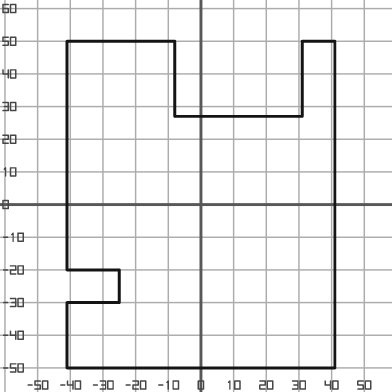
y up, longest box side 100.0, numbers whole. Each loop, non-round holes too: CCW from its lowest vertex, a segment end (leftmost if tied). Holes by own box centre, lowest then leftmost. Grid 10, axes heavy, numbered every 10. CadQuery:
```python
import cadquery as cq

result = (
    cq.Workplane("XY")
    .moveTo(-41.0, -50.0)
    .lineTo(41.0, -50.0)
    .lineTo(41.0, 50.0)
    .lineTo(31.0, 50.0)
    .lineTo(31.0, 27.0)
    .lineTo(-8.0, 27.0)
    .lineTo(-8.0, 50.0)
    .lineTo(-41.0, 50.0)
    .lineTo(-41.0, -20.0)
    .lineTo(-25.0, -20.0)
    .lineTo(-25.0, -30.0)
    .lineTo(-41.0, -30.0)
    .close()
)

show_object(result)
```